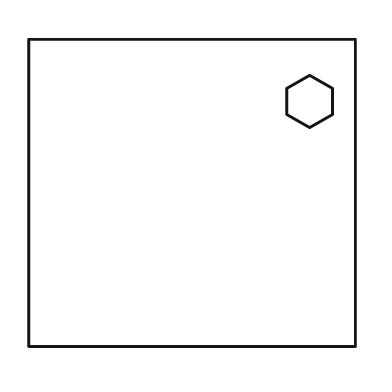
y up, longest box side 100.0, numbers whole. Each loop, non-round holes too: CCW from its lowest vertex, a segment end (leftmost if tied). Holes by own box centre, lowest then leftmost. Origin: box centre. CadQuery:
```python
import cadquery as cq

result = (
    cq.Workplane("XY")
    .moveTo(-50.0, -47.0)
    .lineTo(50.0, -47.0)
    .lineTo(50.0, 47.0)
    .lineTo(-50.0, 47.0)
    .close()
    .moveTo(36.0, 20.0)
    .lineTo(43.0, 24.0)
    .lineTo(43.0, 32.0)
    .lineTo(36.0, 36.0)
    .lineTo(29.0, 32.0)
    .lineTo(29.0, 24.0)
    .close()
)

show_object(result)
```